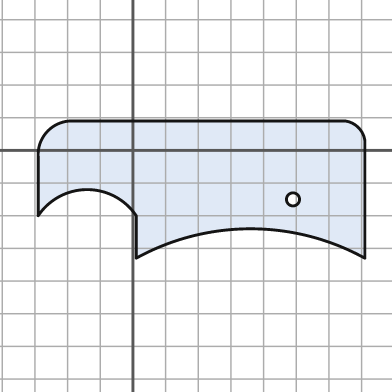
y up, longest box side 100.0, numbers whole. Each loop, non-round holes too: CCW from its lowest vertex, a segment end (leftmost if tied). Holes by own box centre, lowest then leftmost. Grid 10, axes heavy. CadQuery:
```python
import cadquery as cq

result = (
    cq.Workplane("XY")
    .moveTo(1.0, -33.0)
    .threePointArc((36.0, -24.0), (71.0, -33.0))
    .lineTo(71.0, 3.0)
    .threePointArc((69.0, 7.0), (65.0, 9.0))
    .lineTo(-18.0, 9.0)
    .threePointArc((-26.0, 6.0), (-29.0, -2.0))
    .lineTo(-29.0, -20.0)
    .threePointArc((-14.0, -12.0), (1.0, -20.0))
    .close()
    .moveTo(49.0, -15.0)
    .circle(2.0)
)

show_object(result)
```